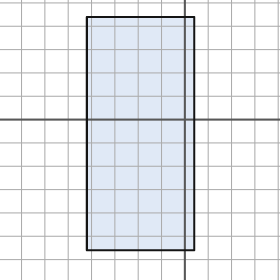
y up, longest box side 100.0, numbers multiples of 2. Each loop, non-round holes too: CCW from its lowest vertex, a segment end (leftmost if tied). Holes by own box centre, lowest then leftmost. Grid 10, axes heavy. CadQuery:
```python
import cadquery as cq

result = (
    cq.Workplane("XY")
    .moveTo(-42.0, -56.0)
    .lineTo(4.0, -56.0)
    .lineTo(4.0, 44.0)
    .lineTo(-42.0, 44.0)
    .close()
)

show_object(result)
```